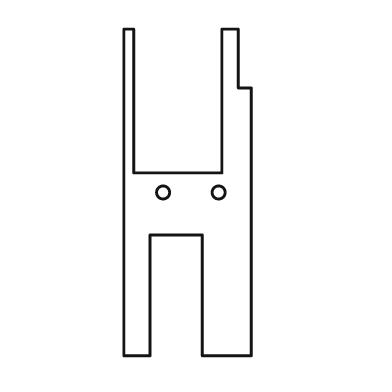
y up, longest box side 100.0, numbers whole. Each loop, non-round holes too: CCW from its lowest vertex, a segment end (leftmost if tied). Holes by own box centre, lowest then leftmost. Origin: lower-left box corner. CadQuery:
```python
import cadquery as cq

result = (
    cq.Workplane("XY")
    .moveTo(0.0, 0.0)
    .lineTo(8.0, 0.0)
    .lineTo(8.0, 37.0)
    .lineTo(24.0, 37.0)
    .lineTo(24.0, 0.0)
    .lineTo(39.0, 0.0)
    .lineTo(39.0, 82.0)
    .lineTo(35.0, 82.0)
    .lineTo(35.0, 100.0)
    .lineTo(30.0, 100.0)
    .lineTo(30.0, 56.0)
    .lineTo(3.0, 56.0)
    .lineTo(3.0, 100.0)
    .lineTo(0.0, 100.0)
    .close()
    .moveTo(12.0, 50.0)
    .circle(2.0)
    .moveTo(29.0, 50.0)
    .circle(2.0)
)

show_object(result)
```